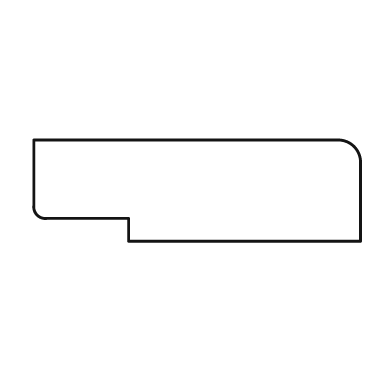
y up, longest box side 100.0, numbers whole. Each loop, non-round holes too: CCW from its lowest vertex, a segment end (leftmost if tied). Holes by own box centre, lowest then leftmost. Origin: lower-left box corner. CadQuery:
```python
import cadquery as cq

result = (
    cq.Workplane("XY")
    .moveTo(29.0, 0.0)
    .lineTo(100.0, 0.0)
    .lineTo(100.0, 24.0)
    .threePointArc((98.0, 29.0), (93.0, 31.0))
    .lineTo(0.0, 31.0)
    .lineTo(0.0, 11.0)
    .threePointArc((1.0, 8.0), (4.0, 7.0))
    .lineTo(29.0, 7.0)
    .close()
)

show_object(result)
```